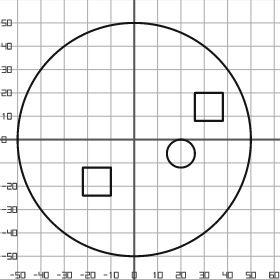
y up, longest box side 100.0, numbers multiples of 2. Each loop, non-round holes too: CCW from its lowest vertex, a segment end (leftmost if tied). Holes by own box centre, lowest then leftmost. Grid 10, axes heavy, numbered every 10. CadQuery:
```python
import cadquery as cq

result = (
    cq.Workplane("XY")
    .moveTo(0.0, 0.0)
    .circle(50.0)
    .moveTo(-22.0, -24.0)
    .lineTo(-10.0, -24.0)
    .lineTo(-10.0, -12.0)
    .lineTo(-22.0, -12.0)
    .close()
    .moveTo(20.0, -6.0)
    .circle(6.0)
    .moveTo(26.0, 8.0)
    .lineTo(38.0, 8.0)
    .lineTo(38.0, 20.0)
    .lineTo(26.0, 20.0)
    .close()
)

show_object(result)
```